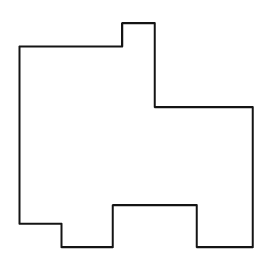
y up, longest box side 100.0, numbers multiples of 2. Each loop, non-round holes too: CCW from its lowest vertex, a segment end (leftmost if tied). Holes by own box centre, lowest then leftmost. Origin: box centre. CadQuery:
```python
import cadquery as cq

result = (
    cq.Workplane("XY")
    .moveTo(-32.0, -48.0)
    .lineTo(-10.0, -48.0)
    .lineTo(-10.0, -30.0)
    .lineTo(26.0, -30.0)
    .lineTo(26.0, -48.0)
    .lineTo(50.0, -48.0)
    .lineTo(50.0, 12.0)
    .lineTo(8.0, 12.0)
    .lineTo(8.0, 48.0)
    .lineTo(-6.0, 48.0)
    .lineTo(-6.0, 38.0)
    .lineTo(-50.0, 38.0)
    .lineTo(-50.0, -38.0)
    .lineTo(-32.0, -38.0)
    .close()
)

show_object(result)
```